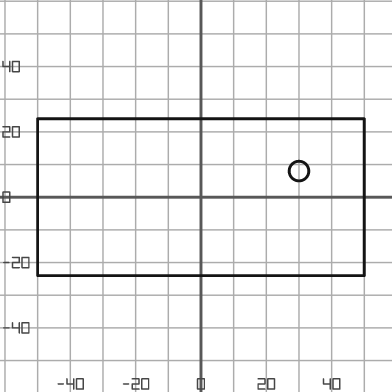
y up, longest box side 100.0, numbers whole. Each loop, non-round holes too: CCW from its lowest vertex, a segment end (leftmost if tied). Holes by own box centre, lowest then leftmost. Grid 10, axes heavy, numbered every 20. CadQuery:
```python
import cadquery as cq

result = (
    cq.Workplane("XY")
    .moveTo(-50.0, -24.0)
    .lineTo(50.0, -24.0)
    .lineTo(50.0, 24.0)
    .lineTo(-50.0, 24.0)
    .close()
    .moveTo(30.0, 8.0)
    .circle(3.0)
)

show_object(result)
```